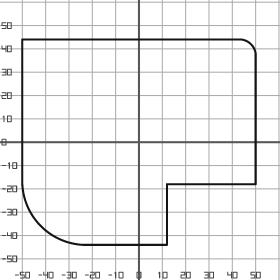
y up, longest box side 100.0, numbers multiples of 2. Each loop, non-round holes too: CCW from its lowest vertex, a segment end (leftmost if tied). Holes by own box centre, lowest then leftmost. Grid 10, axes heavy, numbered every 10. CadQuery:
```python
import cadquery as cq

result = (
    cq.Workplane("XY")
    .moveTo(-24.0, -44.0)
    .lineTo(12.0, -44.0)
    .lineTo(12.0, -18.0)
    .lineTo(50.0, -18.0)
    .lineTo(50.0, 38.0)
    .threePointArc((48.0, 42.0), (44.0, 44.0))
    .lineTo(-50.0, 44.0)
    .lineTo(-50.0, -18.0)
    .threePointArc((-42.0, -36.0), (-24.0, -44.0))
    .close()
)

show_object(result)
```